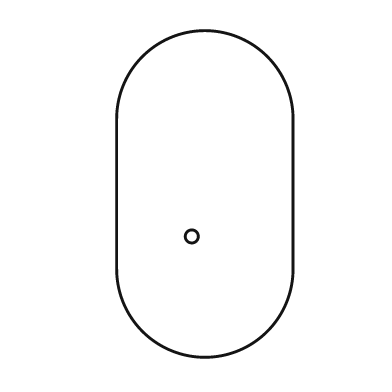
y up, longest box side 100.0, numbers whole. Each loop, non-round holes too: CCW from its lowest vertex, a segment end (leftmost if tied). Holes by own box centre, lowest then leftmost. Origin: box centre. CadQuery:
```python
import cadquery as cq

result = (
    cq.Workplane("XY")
    .moveTo(-27.0, -23.0)
    .threePointArc((0.0, -50.0), (27.0, -23.0))
    .lineTo(27.0, 23.0)
    .threePointArc((0.0, 50.0), (-27.0, 23.0))
    .close()
    .moveTo(-4.0, -13.0)
    .circle(2.0)
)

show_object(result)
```